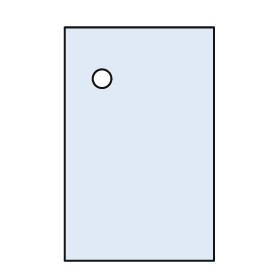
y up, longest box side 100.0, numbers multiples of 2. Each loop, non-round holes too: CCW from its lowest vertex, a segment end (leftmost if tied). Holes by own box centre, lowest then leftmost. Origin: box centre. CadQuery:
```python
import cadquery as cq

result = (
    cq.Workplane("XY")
    .moveTo(-32.0, -50.0)
    .lineTo(32.0, -50.0)
    .lineTo(32.0, 50.0)
    .lineTo(-32.0, 50.0)
    .close()
    .moveTo(-16.0, 28.0)
    .circle(4.0)
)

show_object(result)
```